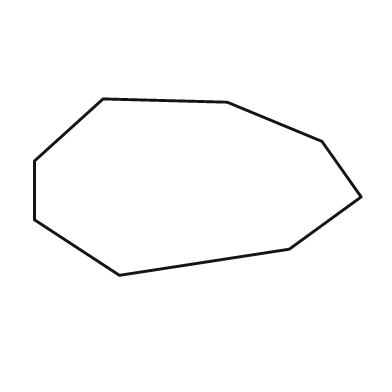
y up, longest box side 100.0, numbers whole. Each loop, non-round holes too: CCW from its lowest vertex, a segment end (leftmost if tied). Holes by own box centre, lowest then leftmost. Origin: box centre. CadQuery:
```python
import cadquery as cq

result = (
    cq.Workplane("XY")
    .moveTo(-24.0, -27.0)
    .lineTo(28.0, -19.0)
    .lineTo(50.0, -3.0)
    .lineTo(38.0, 14.0)
    .lineTo(9.0, 26.0)
    .lineTo(-29.0, 27.0)
    .lineTo(-50.0, 8.0)
    .lineTo(-50.0, -10.0)
    .close()
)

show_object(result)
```